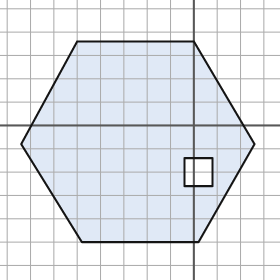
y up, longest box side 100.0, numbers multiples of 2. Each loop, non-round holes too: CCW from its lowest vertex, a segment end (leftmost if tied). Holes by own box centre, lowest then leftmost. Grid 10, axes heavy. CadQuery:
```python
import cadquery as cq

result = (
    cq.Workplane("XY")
    .moveTo(-48.0, -50.0)
    .lineTo(2.0, -50.0)
    .lineTo(26.0, -8.0)
    .lineTo(0.0, 36.0)
    .lineTo(-50.0, 36.0)
    .lineTo(-74.0, -8.0)
    .close()
    .moveTo(-4.0, -26.0)
    .lineTo(8.0, -26.0)
    .lineTo(8.0, -14.0)
    .lineTo(-4.0, -14.0)
    .close()
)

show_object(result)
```